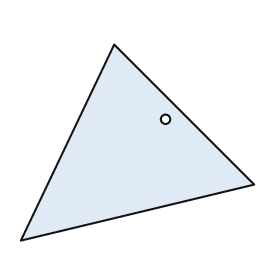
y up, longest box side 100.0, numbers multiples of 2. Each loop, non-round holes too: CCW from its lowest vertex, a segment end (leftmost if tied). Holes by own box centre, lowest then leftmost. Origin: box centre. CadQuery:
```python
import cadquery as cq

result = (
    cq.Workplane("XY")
    .moveTo(-50.0, -42.0)
    .lineTo(50.0, -18.0)
    .lineTo(-10.0, 42.0)
    .close()
    .moveTo(12.0, 10.0)
    .circle(2.0)
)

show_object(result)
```